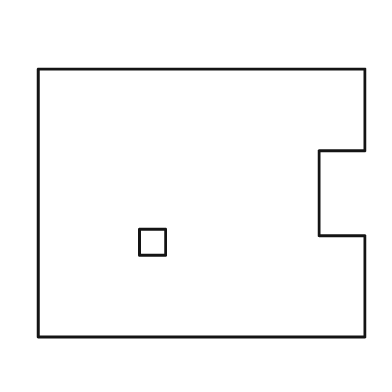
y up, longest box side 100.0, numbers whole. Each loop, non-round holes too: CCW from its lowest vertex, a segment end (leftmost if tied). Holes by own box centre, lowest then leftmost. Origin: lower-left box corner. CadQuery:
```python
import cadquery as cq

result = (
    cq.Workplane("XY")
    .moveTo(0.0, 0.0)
    .lineTo(100.0, 0.0)
    .lineTo(100.0, 31.0)
    .lineTo(86.0, 31.0)
    .lineTo(86.0, 57.0)
    .lineTo(100.0, 57.0)
    .lineTo(100.0, 82.0)
    .lineTo(0.0, 82.0)
    .close()
    .moveTo(31.0, 25.0)
    .lineTo(39.0, 25.0)
    .lineTo(39.0, 33.0)
    .lineTo(31.0, 33.0)
    .close()
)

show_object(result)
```